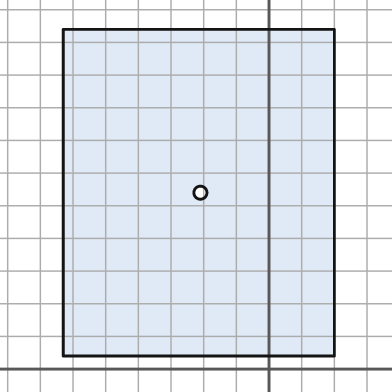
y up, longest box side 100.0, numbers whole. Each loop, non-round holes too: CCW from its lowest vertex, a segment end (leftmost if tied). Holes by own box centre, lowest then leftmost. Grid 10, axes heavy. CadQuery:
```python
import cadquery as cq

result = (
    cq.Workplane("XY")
    .moveTo(-63.0, 4.0)
    .lineTo(20.0, 4.0)
    .lineTo(20.0, 104.0)
    .lineTo(-63.0, 104.0)
    .close()
    .moveTo(-21.0, 54.0)
    .circle(2.0)
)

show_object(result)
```